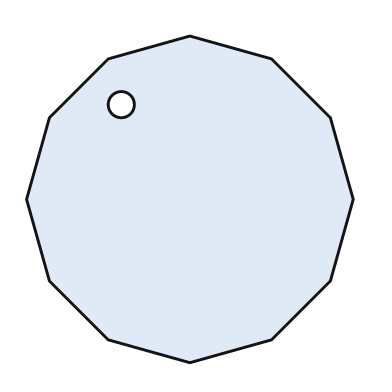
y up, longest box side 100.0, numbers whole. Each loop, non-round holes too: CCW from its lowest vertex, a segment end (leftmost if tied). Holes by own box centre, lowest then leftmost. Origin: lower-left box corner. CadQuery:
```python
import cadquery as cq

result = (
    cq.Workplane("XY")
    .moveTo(50.0, 0.0)
    .lineTo(75.0, 7.0)
    .lineTo(93.0, 25.0)
    .lineTo(100.0, 50.0)
    .lineTo(93.0, 75.0)
    .lineTo(75.0, 93.0)
    .lineTo(50.0, 100.0)
    .lineTo(25.0, 93.0)
    .lineTo(7.0, 75.0)
    .lineTo(0.0, 50.0)
    .lineTo(7.0, 25.0)
    .lineTo(25.0, 7.0)
    .close()
    .moveTo(29.0, 79.0)
    .circle(4.0)
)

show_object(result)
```